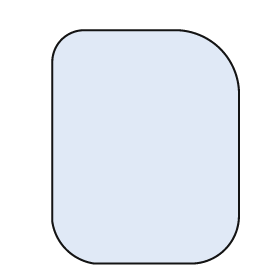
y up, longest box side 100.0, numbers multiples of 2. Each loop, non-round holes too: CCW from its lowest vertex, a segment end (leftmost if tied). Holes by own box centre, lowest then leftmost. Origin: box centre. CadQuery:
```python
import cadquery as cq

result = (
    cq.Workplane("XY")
    .moveTo(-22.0, -50.0)
    .lineTo(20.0, -50.0)
    .threePointArc((34.0, -44.0), (40.0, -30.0))
    .lineTo(40.0, 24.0)
    .threePointArc((32.0, 42.0), (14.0, 50.0))
    .lineTo(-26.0, 50.0)
    .threePointArc((-36.0, 46.0), (-40.0, 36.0))
    .lineTo(-40.0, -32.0)
    .threePointArc((-34.0, -44.0), (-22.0, -50.0))
    .close()
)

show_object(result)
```